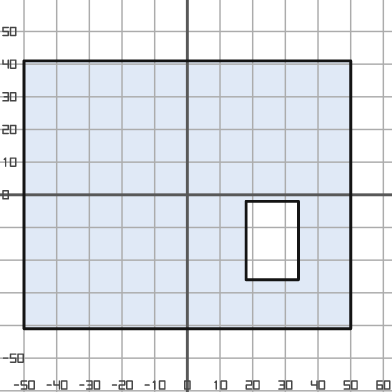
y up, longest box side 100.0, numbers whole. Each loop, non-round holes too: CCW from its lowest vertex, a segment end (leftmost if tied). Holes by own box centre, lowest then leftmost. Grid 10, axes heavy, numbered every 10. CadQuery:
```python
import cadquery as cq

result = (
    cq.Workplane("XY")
    .moveTo(-50.0, -41.0)
    .lineTo(50.0, -41.0)
    .lineTo(50.0, 41.0)
    .lineTo(-50.0, 41.0)
    .close()
    .moveTo(18.0, -26.0)
    .lineTo(34.0, -26.0)
    .lineTo(34.0, -2.0)
    .lineTo(18.0, -2.0)
    .close()
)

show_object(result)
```